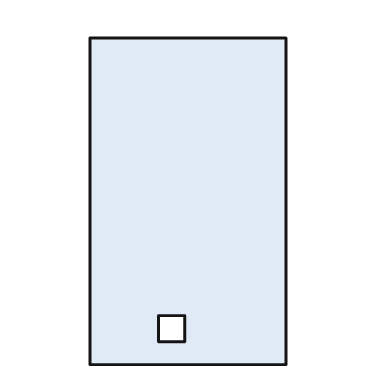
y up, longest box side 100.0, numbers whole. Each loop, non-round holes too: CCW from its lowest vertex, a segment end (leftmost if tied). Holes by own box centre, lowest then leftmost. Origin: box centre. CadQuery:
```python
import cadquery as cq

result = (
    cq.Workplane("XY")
    .moveTo(-30.0, -50.0)
    .lineTo(30.0, -50.0)
    .lineTo(30.0, 50.0)
    .lineTo(-30.0, 50.0)
    .close()
    .moveTo(-9.0, -43.0)
    .lineTo(-1.0, -43.0)
    .lineTo(-1.0, -35.0)
    .lineTo(-9.0, -35.0)
    .close()
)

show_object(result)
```